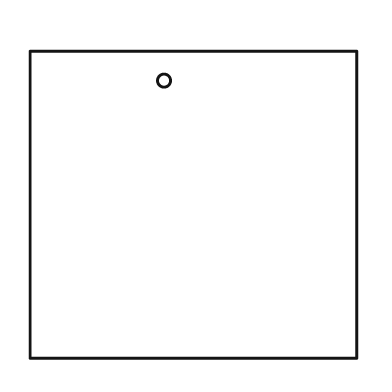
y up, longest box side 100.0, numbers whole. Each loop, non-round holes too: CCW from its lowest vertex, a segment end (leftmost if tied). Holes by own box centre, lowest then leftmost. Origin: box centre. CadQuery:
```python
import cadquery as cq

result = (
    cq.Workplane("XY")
    .moveTo(-50.0, -47.0)
    .lineTo(50.0, -47.0)
    .lineTo(50.0, 47.0)
    .lineTo(-50.0, 47.0)
    .close()
    .moveTo(-9.0, 38.0)
    .circle(2.0)
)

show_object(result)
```